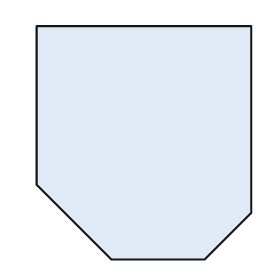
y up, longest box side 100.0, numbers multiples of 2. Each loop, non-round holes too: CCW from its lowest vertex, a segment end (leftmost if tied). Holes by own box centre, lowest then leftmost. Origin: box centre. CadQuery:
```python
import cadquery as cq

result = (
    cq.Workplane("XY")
    .moveTo(-14.0, -50.0)
    .lineTo(26.0, -50.0)
    .lineTo(46.0, -30.0)
    .lineTo(46.0, 50.0)
    .lineTo(-46.0, 50.0)
    .lineTo(-46.0, -18.0)
    .close()
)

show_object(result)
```